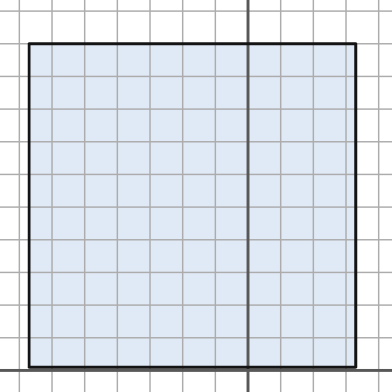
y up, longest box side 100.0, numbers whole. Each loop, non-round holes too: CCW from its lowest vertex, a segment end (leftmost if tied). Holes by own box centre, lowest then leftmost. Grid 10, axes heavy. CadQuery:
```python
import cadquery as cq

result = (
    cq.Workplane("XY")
    .moveTo(-67.0, 1.0)
    .lineTo(33.0, 1.0)
    .lineTo(33.0, 100.0)
    .lineTo(-67.0, 100.0)
    .close()
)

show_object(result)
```